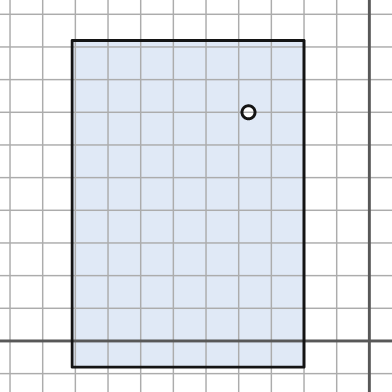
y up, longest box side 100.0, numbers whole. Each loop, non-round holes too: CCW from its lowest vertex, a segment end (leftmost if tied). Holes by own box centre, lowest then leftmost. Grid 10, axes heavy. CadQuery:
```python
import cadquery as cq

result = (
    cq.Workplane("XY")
    .moveTo(-91.0, -8.0)
    .lineTo(-20.0, -8.0)
    .lineTo(-20.0, 92.0)
    .lineTo(-91.0, 92.0)
    .close()
    .moveTo(-37.0, 70.0)
    .circle(2.0)
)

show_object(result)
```